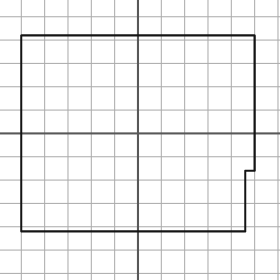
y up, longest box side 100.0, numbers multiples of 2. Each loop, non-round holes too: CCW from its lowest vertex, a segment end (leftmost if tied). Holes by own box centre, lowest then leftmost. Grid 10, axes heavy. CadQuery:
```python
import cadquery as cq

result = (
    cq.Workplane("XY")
    .moveTo(-50.0, -42.0)
    .lineTo(46.0, -42.0)
    .lineTo(46.0, -16.0)
    .lineTo(50.0, -16.0)
    .lineTo(50.0, 42.0)
    .lineTo(-50.0, 42.0)
    .close()
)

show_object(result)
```